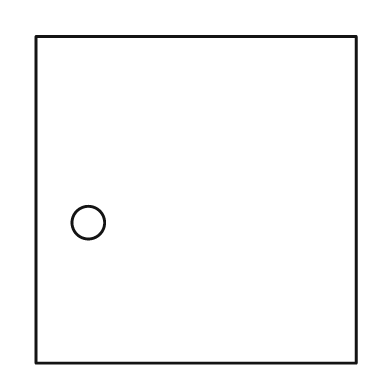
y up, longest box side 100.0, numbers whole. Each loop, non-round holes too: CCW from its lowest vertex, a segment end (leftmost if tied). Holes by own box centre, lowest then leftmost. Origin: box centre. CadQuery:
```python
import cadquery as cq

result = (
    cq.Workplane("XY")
    .moveTo(-49.0, -50.0)
    .lineTo(49.0, -50.0)
    .lineTo(49.0, 50.0)
    .lineTo(-49.0, 50.0)
    .close()
    .moveTo(-33.0, -7.0)
    .circle(5.0)
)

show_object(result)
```